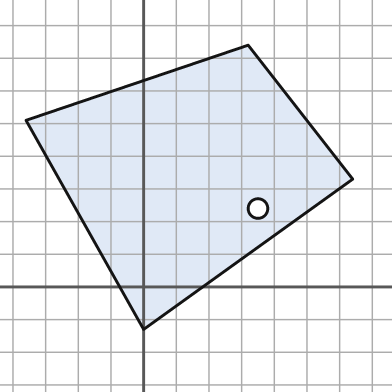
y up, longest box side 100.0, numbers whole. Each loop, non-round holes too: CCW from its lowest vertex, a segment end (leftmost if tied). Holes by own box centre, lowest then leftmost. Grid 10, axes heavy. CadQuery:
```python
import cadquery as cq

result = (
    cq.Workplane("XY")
    .moveTo(0.0, -13.0)
    .lineTo(64.0, 33.0)
    .lineTo(32.0, 74.0)
    .lineTo(-36.0, 51.0)
    .close()
    .moveTo(35.0, 24.0)
    .circle(3.0)
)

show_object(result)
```